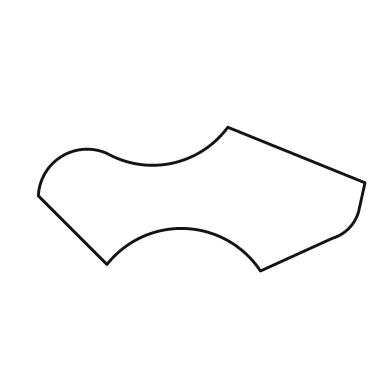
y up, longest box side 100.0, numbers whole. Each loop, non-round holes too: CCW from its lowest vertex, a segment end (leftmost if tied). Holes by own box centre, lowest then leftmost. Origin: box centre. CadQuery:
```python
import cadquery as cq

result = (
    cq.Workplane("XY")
    .moveTo(18.0, -22.0)
    .lineTo(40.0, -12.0)
    .threePointArc((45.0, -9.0), (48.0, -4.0))
    .lineTo(50.0, 5.0)
    .lineTo(8.0, 22.0)
    .threePointArc((-9.0, 11.0), (-29.0, 14.0))
    .threePointArc((-43.0, 13.0), (-50.0, 1.0))
    .lineTo(-29.0, -20.0)
    .threePointArc((-5.0, -9.0), (18.0, -22.0))
    .close()
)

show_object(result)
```